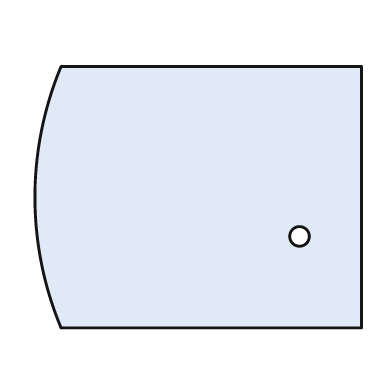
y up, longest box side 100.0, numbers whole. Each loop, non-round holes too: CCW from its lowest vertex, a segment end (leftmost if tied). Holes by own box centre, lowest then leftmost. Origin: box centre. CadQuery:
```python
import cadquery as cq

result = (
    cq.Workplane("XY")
    .moveTo(-42.0, -40.0)
    .lineTo(50.0, -40.0)
    .lineTo(50.0, 40.0)
    .lineTo(-42.0, 40.0)
    .threePointArc((-50.0, 0.0), (-42.0, -40.0))
    .close()
    .moveTo(31.0, -12.0)
    .circle(3.0)
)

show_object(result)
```